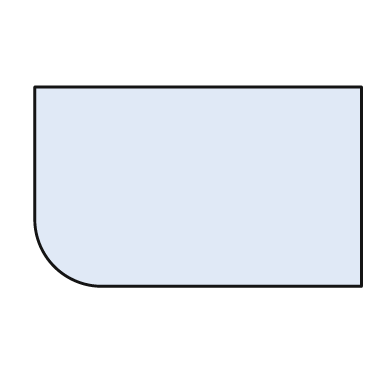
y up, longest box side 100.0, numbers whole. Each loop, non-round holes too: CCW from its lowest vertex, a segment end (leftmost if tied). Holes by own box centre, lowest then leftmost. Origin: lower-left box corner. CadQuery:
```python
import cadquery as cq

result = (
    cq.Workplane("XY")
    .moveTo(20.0, 0.0)
    .lineTo(100.0, 0.0)
    .lineTo(100.0, 61.0)
    .lineTo(0.0, 61.0)
    .lineTo(0.0, 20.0)
    .threePointArc((6.0, 6.0), (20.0, 0.0))
    .close()
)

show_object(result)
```